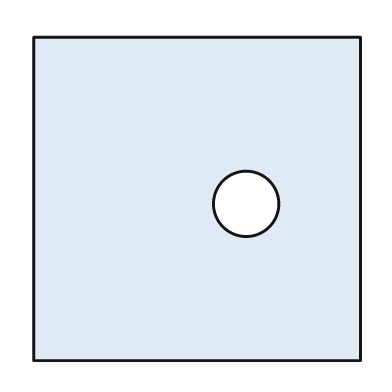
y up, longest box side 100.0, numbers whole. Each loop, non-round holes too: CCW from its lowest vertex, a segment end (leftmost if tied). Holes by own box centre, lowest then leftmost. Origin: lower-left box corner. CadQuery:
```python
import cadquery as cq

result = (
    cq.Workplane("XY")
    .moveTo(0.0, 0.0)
    .lineTo(100.0, 0.0)
    .lineTo(100.0, 99.0)
    .lineTo(0.0, 99.0)
    .close()
    .moveTo(65.0, 48.0)
    .circle(10.0)
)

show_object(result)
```